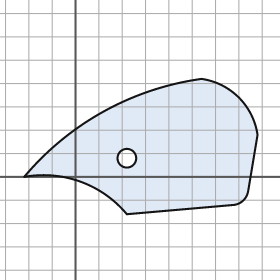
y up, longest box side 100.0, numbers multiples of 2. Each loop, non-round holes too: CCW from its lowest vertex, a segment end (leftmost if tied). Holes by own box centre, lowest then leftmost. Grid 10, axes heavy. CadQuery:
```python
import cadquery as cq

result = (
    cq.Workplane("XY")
    .moveTo(22.0, -16.0)
    .lineTo(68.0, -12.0)
    .threePointArc((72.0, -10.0), (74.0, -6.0))
    .lineTo(78.0, 18.0)
    .threePointArc((70.0, 34.0), (54.0, 42.0))
    .threePointArc((12.0, 28.0), (-22.0, 0.0))
    .threePointArc((2.0, -2.0), (22.0, -16.0))
    .close()
    .moveTo(22.0, 8.0)
    .circle(4.0)
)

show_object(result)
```